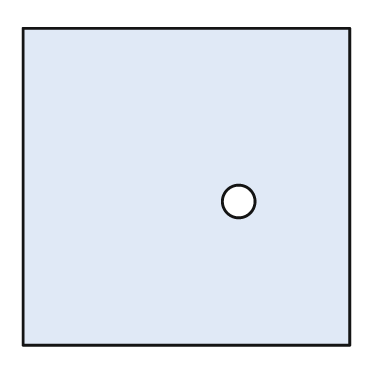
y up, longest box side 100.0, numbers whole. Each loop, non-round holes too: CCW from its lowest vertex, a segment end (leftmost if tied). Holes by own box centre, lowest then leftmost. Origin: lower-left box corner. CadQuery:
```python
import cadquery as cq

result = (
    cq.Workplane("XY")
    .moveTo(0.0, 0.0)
    .lineTo(100.0, 0.0)
    .lineTo(100.0, 97.0)
    .lineTo(0.0, 97.0)
    .close()
    .moveTo(66.0, 44.0)
    .circle(5.0)
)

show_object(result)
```